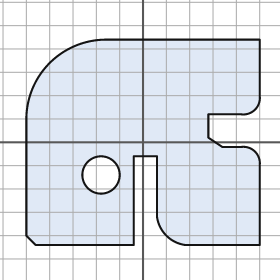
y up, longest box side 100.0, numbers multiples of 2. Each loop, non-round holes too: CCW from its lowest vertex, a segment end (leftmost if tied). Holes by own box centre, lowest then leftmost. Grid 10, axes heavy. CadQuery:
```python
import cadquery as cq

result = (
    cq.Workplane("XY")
    .moveTo(-46.0, -44.0)
    .lineTo(-4.0, -44.0)
    .lineTo(-4.0, -6.0)
    .lineTo(6.0, -6.0)
    .lineTo(6.0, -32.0)
    .threePointArc((10.0, -40.0), (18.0, -44.0))
    .lineTo(50.0, -44.0)
    .lineTo(50.0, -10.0)
    .threePointArc((48.0, -4.0), (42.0, -2.0))
    .lineTo(34.0, -2.0)
    .lineTo(28.0, 2.0)
    .lineTo(28.0, 12.0)
    .lineTo(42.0, 12.0)
    .threePointArc((48.0, 14.0), (50.0, 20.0))
    .lineTo(50.0, 44.0)
    .lineTo(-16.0, 44.0)
    .threePointArc((-40.0, 34.0), (-50.0, 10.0))
    .lineTo(-50.0, -40.0)
    .close()
    .moveTo(-18.0, -14.0)
    .circle(8.0)
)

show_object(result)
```